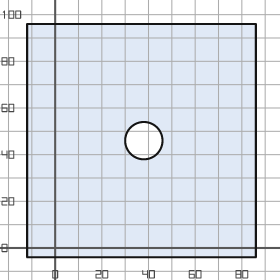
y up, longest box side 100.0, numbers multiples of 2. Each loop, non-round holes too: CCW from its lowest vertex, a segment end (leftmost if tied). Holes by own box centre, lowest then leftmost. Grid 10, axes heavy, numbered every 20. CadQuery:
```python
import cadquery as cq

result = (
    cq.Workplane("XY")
    .moveTo(-12.0, -4.0)
    .lineTo(86.0, -4.0)
    .lineTo(86.0, 96.0)
    .lineTo(-12.0, 96.0)
    .close()
    .moveTo(38.0, 46.0)
    .circle(8.0)
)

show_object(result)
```